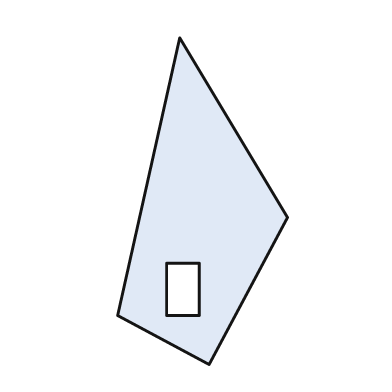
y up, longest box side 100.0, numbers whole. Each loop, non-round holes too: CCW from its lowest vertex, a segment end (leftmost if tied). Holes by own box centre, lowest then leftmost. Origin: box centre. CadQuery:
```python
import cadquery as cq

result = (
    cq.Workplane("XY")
    .moveTo(2.0, -50.0)
    .lineTo(26.0, -5.0)
    .lineTo(-7.0, 50.0)
    .lineTo(-26.0, -35.0)
    .close()
    .moveTo(-11.0, -35.0)
    .lineTo(-1.0, -35.0)
    .lineTo(-1.0, -19.0)
    .lineTo(-11.0, -19.0)
    .close()
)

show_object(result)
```